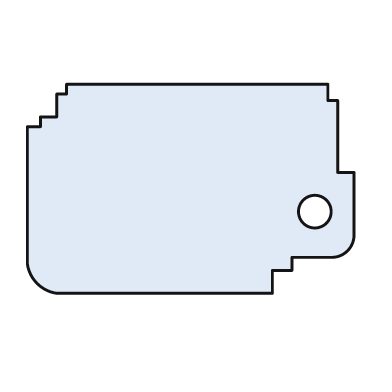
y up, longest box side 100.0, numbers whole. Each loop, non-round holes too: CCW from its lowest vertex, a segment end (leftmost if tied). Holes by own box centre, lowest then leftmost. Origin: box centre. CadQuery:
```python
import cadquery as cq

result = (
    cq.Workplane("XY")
    .moveTo(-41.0, -32.0)
    .lineTo(25.0, -32.0)
    .lineTo(25.0, -25.0)
    .lineTo(31.0, -25.0)
    .lineTo(31.0, -21.0)
    .lineTo(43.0, -21.0)
    .threePointArc((48.0, -19.0), (50.0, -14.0))
    .lineTo(50.0, 5.0)
    .lineTo(45.0, 5.0)
    .lineTo(45.0, 27.0)
    .lineTo(42.0, 27.0)
    .lineTo(42.0, 32.0)
    .lineTo(-38.0, 32.0)
    .lineTo(-38.0, 29.0)
    .lineTo(-41.0, 29.0)
    .lineTo(-41.0, 22.0)
    .lineTo(-46.0, 22.0)
    .lineTo(-46.0, 19.0)
    .lineTo(-50.0, 19.0)
    .lineTo(-50.0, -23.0)
    .threePointArc((-47.0, -29.0), (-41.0, -32.0))
    .close()
    .moveTo(38.0, -7.0)
    .circle(5.0)
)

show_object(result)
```